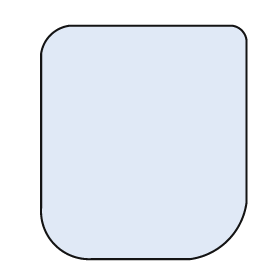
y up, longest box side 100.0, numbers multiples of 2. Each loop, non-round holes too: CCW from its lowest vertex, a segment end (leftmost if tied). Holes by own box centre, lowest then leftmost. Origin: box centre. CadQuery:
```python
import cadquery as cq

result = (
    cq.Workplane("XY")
    .moveTo(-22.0, -50.0)
    .lineTo(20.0, -50.0)
    .threePointArc((36.0, -42.0), (44.0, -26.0))
    .lineTo(44.0, 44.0)
    .threePointArc((42.0, 48.0), (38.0, 50.0))
    .lineTo(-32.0, 50.0)
    .threePointArc((-40.0, 46.0), (-44.0, 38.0))
    .lineTo(-44.0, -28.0)
    .threePointArc((-38.0, -44.0), (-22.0, -50.0))
    .close()
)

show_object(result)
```